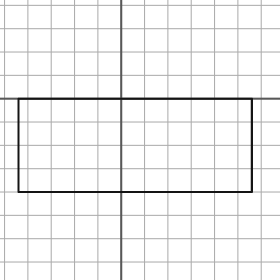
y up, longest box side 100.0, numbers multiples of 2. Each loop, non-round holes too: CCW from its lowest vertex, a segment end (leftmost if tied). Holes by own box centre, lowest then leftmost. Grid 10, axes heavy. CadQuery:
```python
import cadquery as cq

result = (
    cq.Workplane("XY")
    .moveTo(-44.0, -40.0)
    .lineTo(56.0, -40.0)
    .lineTo(56.0, 0.0)
    .lineTo(-44.0, 0.0)
    .close()
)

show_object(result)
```